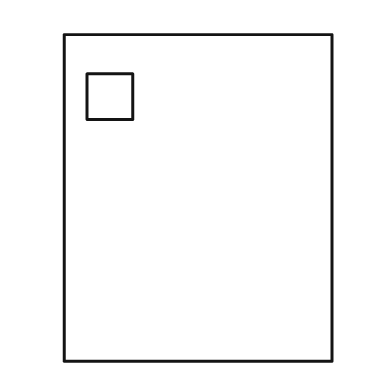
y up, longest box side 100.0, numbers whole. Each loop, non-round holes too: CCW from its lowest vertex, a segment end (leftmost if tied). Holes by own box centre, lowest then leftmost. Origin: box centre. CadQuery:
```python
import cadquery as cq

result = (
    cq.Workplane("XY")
    .moveTo(-41.0, -50.0)
    .lineTo(41.0, -50.0)
    .lineTo(41.0, 50.0)
    .lineTo(-41.0, 50.0)
    .close()
    .moveTo(-34.0, 24.0)
    .lineTo(-20.0, 24.0)
    .lineTo(-20.0, 38.0)
    .lineTo(-34.0, 38.0)
    .close()
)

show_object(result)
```